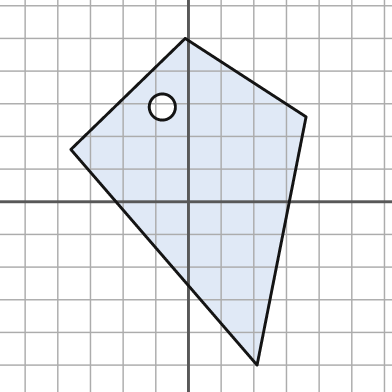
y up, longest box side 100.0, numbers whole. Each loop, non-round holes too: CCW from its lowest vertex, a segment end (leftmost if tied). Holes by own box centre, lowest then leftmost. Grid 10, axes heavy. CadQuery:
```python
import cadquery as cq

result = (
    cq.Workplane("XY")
    .moveTo(21.0, -50.0)
    .lineTo(36.0, 26.0)
    .lineTo(-1.0, 50.0)
    .lineTo(-36.0, 16.0)
    .close()
    .moveTo(-8.0, 29.0)
    .circle(4.0)
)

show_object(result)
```